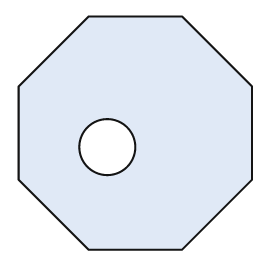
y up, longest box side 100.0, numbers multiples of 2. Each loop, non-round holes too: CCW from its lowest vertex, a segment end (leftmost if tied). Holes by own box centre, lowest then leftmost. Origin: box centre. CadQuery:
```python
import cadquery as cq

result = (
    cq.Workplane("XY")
    .moveTo(-20.0, -50.0)
    .lineTo(20.0, -50.0)
    .lineTo(50.0, -20.0)
    .lineTo(50.0, 20.0)
    .lineTo(20.0, 50.0)
    .lineTo(-20.0, 50.0)
    .lineTo(-50.0, 20.0)
    .lineTo(-50.0, -20.0)
    .close()
    .moveTo(-12.0, -6.0)
    .circle(12.0)
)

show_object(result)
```